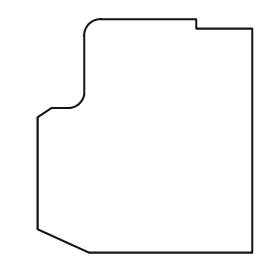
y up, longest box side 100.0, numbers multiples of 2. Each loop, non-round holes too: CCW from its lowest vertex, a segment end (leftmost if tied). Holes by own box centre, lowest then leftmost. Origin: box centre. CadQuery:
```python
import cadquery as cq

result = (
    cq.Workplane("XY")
    .moveTo(-24.0, -50.0)
    .lineTo(46.0, -50.0)
    .lineTo(46.0, 46.0)
    .lineTo(22.0, 46.0)
    .lineTo(22.0, 50.0)
    .lineTo(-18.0, 50.0)
    .threePointArc((-24.0, 48.0), (-26.0, 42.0))
    .lineTo(-26.0, 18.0)
    .threePointArc((-28.0, 14.0), (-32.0, 12.0))
    .lineTo(-40.0, 12.0)
    .lineTo(-46.0, 8.0)
    .lineTo(-46.0, -40.0)
    .close()
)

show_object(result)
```